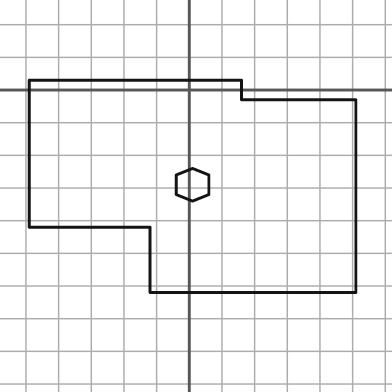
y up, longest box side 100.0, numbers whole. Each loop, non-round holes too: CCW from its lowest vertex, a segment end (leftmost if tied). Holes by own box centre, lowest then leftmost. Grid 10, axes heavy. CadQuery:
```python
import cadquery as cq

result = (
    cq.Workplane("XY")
    .moveTo(-12.0, -62.0)
    .lineTo(51.0, -62.0)
    .lineTo(51.0, -3.0)
    .lineTo(16.0, -3.0)
    .lineTo(16.0, 3.0)
    .lineTo(-49.0, 3.0)
    .lineTo(-49.0, -42.0)
    .lineTo(-12.0, -42.0)
    .close()
    .moveTo(1.0, -34.0)
    .lineTo(6.0, -32.0)
    .lineTo(6.0, -26.0)
    .lineTo(1.0, -24.0)
    .lineTo(-4.0, -26.0)
    .lineTo(-4.0, -32.0)
    .close()
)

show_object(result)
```